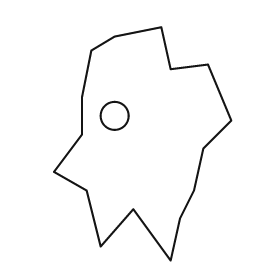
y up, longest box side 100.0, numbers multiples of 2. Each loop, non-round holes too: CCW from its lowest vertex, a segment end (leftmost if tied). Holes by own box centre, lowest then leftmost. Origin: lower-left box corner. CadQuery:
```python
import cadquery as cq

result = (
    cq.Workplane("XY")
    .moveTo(50.0, 0.0)
    .lineTo(54.0, 18.0)
    .lineTo(60.0, 30.0)
    .lineTo(64.0, 48.0)
    .lineTo(76.0, 60.0)
    .lineTo(66.0, 84.0)
    .lineTo(50.0, 82.0)
    .lineTo(46.0, 100.0)
    .lineTo(26.0, 96.0)
    .lineTo(16.0, 90.0)
    .lineTo(12.0, 70.0)
    .lineTo(12.0, 54.0)
    .lineTo(0.0, 38.0)
    .lineTo(14.0, 30.0)
    .lineTo(20.0, 6.0)
    .lineTo(34.0, 22.0)
    .close()
    .moveTo(26.0, 62.0)
    .circle(6.0)
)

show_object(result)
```